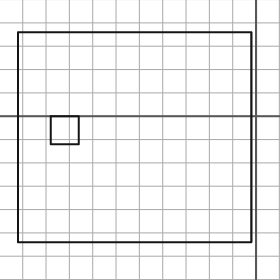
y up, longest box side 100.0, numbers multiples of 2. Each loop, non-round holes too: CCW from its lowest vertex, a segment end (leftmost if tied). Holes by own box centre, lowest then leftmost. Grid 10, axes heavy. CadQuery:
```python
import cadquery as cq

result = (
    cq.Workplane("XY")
    .moveTo(-102.0, -54.0)
    .lineTo(-2.0, -54.0)
    .lineTo(-2.0, 36.0)
    .lineTo(-102.0, 36.0)
    .close()
    .moveTo(-88.0, -12.0)
    .lineTo(-76.0, -12.0)
    .lineTo(-76.0, 0.0)
    .lineTo(-88.0, 0.0)
    .close()
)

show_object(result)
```